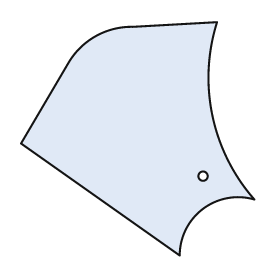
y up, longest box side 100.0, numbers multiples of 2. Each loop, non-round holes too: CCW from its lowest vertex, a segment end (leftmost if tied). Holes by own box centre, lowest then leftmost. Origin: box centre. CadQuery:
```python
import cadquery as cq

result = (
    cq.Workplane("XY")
    .moveTo(18.0, -50.0)
    .threePointArc((28.0, -30.0), (50.0, -26.0))
    .threePointArc((32.0, 10.0), (34.0, 50.0))
    .lineTo(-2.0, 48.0)
    .threePointArc((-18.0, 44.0), (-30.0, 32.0))
    .lineTo(-50.0, -2.0)
    .close()
    .moveTo(28.0, -16.0)
    .circle(2.0)
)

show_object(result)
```